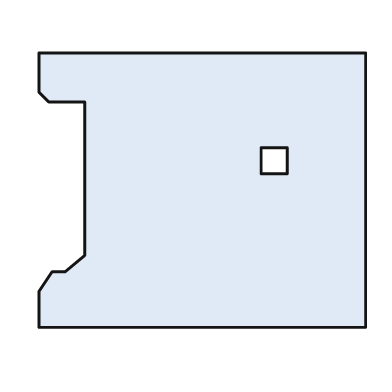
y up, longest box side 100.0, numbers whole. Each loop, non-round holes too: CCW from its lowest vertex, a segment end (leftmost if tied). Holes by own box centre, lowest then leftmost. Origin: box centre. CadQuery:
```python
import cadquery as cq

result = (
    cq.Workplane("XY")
    .moveTo(-50.0, -42.0)
    .lineTo(50.0, -42.0)
    .lineTo(50.0, 42.0)
    .lineTo(-50.0, 42.0)
    .lineTo(-50.0, 30.0)
    .lineTo(-47.0, 27.0)
    .lineTo(-36.0, 27.0)
    .lineTo(-36.0, -20.0)
    .lineTo(-42.0, -25.0)
    .lineTo(-46.0, -25.0)
    .lineTo(-50.0, -31.0)
    .close()
    .moveTo(18.0, 5.0)
    .lineTo(26.0, 5.0)
    .lineTo(26.0, 13.0)
    .lineTo(18.0, 13.0)
    .close()
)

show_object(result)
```